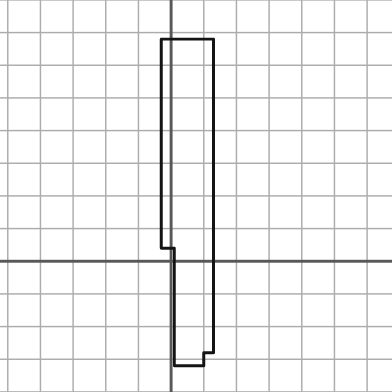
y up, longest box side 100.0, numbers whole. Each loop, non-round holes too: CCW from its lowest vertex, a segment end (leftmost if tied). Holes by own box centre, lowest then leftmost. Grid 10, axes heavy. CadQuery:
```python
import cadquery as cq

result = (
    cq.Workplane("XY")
    .moveTo(1.0, -32.0)
    .lineTo(10.0, -32.0)
    .lineTo(10.0, -28.0)
    .lineTo(13.0, -28.0)
    .lineTo(13.0, 68.0)
    .lineTo(-3.0, 68.0)
    .lineTo(-3.0, 4.0)
    .lineTo(1.0, 4.0)
    .close()
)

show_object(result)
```